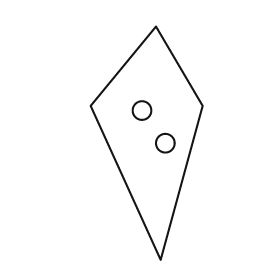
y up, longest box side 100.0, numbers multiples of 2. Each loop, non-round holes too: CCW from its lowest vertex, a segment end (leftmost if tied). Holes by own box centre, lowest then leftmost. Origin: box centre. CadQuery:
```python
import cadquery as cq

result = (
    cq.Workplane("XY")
    .moveTo(6.0, -50.0)
    .lineTo(24.0, 16.0)
    .lineTo(4.0, 50.0)
    .lineTo(-24.0, 16.0)
    .close()
    .moveTo(8.0, 0.0)
    .circle(4.0)
    .moveTo(-2.0, 14.0)
    .circle(4.0)
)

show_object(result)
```